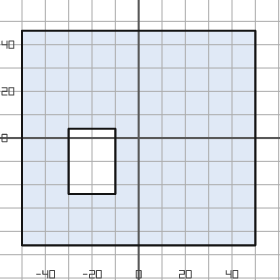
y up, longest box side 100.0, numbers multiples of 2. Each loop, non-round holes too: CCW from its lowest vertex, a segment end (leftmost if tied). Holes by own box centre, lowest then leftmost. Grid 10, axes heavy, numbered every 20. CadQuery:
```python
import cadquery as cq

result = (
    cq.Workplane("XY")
    .moveTo(-50.0, -46.0)
    .lineTo(50.0, -46.0)
    .lineTo(50.0, 46.0)
    .lineTo(-50.0, 46.0)
    .close()
    .moveTo(-30.0, -24.0)
    .lineTo(-10.0, -24.0)
    .lineTo(-10.0, 4.0)
    .lineTo(-30.0, 4.0)
    .close()
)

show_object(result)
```